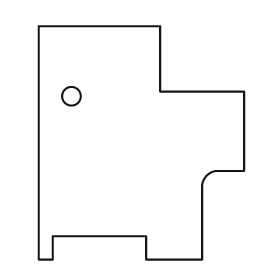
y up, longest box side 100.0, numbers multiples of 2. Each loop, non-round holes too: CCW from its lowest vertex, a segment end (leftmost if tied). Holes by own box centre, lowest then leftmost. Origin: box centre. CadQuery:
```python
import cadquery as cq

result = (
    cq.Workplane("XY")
    .moveTo(-44.0, -50.0)
    .lineTo(-38.0, -50.0)
    .lineTo(-38.0, -40.0)
    .lineTo(2.0, -40.0)
    .lineTo(2.0, -50.0)
    .lineTo(26.0, -50.0)
    .lineTo(26.0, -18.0)
    .threePointArc((28.0, -14.0), (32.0, -12.0))
    .lineTo(44.0, -12.0)
    .lineTo(44.0, 22.0)
    .lineTo(8.0, 22.0)
    .lineTo(8.0, 50.0)
    .lineTo(-44.0, 50.0)
    .close()
    .moveTo(-30.0, 20.0)
    .circle(4.0)
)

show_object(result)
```